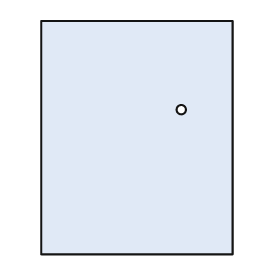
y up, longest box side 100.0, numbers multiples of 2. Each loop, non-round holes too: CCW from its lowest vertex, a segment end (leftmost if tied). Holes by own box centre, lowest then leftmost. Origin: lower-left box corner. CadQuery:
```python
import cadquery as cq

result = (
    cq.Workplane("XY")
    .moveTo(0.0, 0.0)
    .lineTo(82.0, 0.0)
    .lineTo(82.0, 100.0)
    .lineTo(0.0, 100.0)
    .close()
    .moveTo(60.0, 62.0)
    .circle(2.0)
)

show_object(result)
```